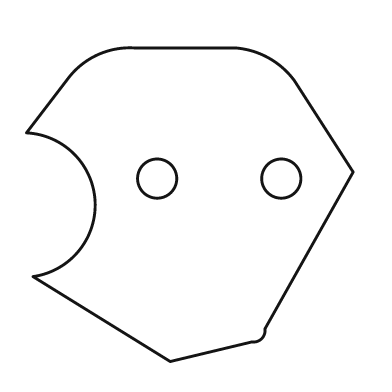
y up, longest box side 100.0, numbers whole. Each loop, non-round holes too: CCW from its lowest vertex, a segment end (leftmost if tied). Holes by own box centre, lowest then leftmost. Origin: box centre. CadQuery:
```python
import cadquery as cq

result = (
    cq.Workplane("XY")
    .moveTo(-6.0, -48.0)
    .lineTo(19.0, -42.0)
    .threePointArc((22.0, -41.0), (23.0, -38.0))
    .lineTo(50.0, 10.0)
    .lineTo(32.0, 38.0)
    .threePointArc((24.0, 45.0), (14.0, 48.0))
    .lineTo(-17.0, 48.0)
    .threePointArc((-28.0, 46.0), (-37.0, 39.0))
    .lineTo(-50.0, 22.0)
    .threePointArc((-29.0, 1.0), (-48.0, -22.0))
    .close()
    .moveTo(-10.0, 8.0)
    .circle(6.0)
    .moveTo(28.0, 8.0)
    .circle(6.0)
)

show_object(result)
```